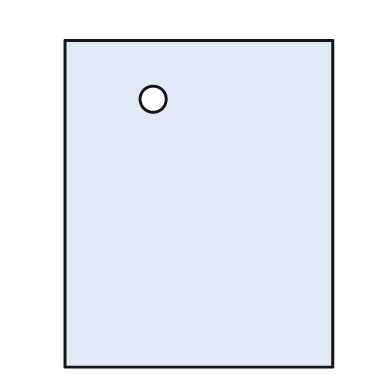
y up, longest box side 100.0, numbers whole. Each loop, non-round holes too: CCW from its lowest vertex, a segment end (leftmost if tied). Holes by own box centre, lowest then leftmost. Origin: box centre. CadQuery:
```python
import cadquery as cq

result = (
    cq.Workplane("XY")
    .moveTo(-41.0, -50.0)
    .lineTo(41.0, -50.0)
    .lineTo(41.0, 50.0)
    .lineTo(-41.0, 50.0)
    .close()
    .moveTo(-14.0, 32.0)
    .circle(4.0)
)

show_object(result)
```